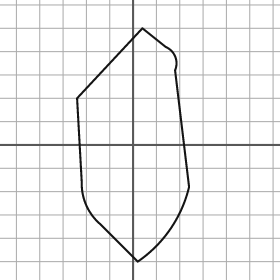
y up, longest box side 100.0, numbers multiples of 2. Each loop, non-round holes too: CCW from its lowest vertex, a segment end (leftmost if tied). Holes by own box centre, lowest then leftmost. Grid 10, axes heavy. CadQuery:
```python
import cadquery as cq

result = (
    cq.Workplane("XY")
    .moveTo(2.0, -50.0)
    .threePointArc((16.0, -36.0), (24.0, -18.0))
    .lineTo(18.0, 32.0)
    .threePointArc((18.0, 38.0), (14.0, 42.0))
    .lineTo(4.0, 50.0)
    .lineTo(-24.0, 20.0)
    .lineTo(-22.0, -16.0)
    .threePointArc((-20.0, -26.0), (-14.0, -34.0))
    .close()
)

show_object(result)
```